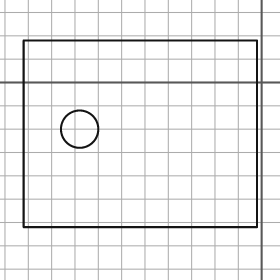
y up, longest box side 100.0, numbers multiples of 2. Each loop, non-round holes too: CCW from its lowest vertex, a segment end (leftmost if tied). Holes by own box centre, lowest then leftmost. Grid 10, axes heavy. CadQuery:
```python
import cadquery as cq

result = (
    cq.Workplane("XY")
    .moveTo(-102.0, -62.0)
    .lineTo(-2.0, -62.0)
    .lineTo(-2.0, 18.0)
    .lineTo(-102.0, 18.0)
    .close()
    .moveTo(-78.0, -20.0)
    .circle(8.0)
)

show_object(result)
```